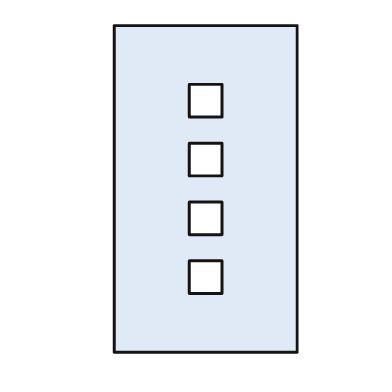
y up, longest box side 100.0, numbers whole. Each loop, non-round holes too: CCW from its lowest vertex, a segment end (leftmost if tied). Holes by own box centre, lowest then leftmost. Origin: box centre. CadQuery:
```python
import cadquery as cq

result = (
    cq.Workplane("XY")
    .moveTo(-28.0, -50.0)
    .lineTo(28.0, -50.0)
    .lineTo(28.0, 50.0)
    .lineTo(-28.0, 50.0)
    .close()
    .moveTo(-5.0, -32.0)
    .lineTo(5.0, -32.0)
    .lineTo(5.0, -22.0)
    .lineTo(-5.0, -22.0)
    .close()
    .moveTo(-5.0, -14.0)
    .lineTo(5.0, -14.0)
    .lineTo(5.0, -4.0)
    .lineTo(-5.0, -4.0)
    .close()
    .moveTo(-5.0, 4.0)
    .lineTo(5.0, 4.0)
    .lineTo(5.0, 14.0)
    .lineTo(-5.0, 14.0)
    .close()
    .moveTo(-5.0, 22.0)
    .lineTo(5.0, 22.0)
    .lineTo(5.0, 32.0)
    .lineTo(-5.0, 32.0)
    .close()
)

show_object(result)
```